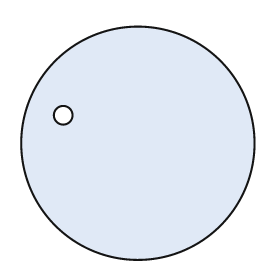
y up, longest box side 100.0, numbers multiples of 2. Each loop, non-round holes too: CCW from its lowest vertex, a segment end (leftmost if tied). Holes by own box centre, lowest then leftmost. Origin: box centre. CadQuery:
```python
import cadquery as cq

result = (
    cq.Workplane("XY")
    .moveTo(0.0, 0.0)
    .circle(50.0)
    .moveTo(-32.0, 12.0)
    .circle(4.0)
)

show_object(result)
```